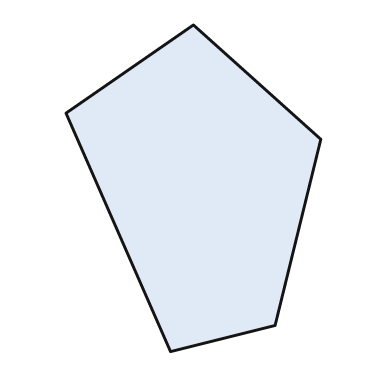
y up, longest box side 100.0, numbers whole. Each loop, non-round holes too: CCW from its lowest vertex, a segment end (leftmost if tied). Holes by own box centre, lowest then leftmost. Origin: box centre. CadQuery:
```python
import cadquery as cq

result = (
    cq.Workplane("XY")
    .moveTo(-7.0, -50.0)
    .lineTo(25.0, -42.0)
    .lineTo(39.0, 15.0)
    .lineTo(0.0, 50.0)
    .lineTo(-39.0, 23.0)
    .close()
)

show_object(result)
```